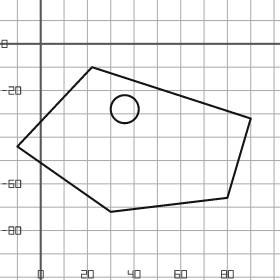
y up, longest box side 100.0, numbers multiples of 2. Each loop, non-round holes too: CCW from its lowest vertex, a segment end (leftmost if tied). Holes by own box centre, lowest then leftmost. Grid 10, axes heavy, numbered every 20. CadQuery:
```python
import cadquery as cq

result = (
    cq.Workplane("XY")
    .moveTo(30.0, -72.0)
    .lineTo(80.0, -66.0)
    .lineTo(90.0, -32.0)
    .lineTo(22.0, -10.0)
    .lineTo(-10.0, -44.0)
    .close()
    .moveTo(36.0, -28.0)
    .circle(6.0)
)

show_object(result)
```